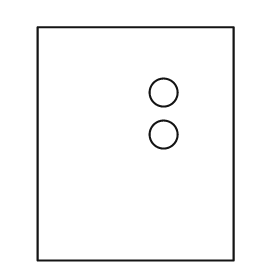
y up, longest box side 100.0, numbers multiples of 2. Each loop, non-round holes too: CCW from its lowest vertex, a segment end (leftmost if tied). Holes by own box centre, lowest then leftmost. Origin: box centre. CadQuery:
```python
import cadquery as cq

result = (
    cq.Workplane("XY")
    .moveTo(-42.0, -50.0)
    .lineTo(42.0, -50.0)
    .lineTo(42.0, 50.0)
    .lineTo(-42.0, 50.0)
    .close()
    .moveTo(12.0, 4.0)
    .circle(6.0)
    .moveTo(12.0, 22.0)
    .circle(6.0)
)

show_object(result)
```